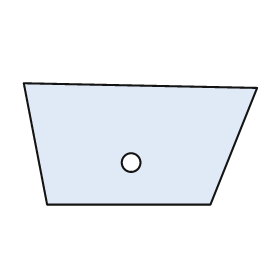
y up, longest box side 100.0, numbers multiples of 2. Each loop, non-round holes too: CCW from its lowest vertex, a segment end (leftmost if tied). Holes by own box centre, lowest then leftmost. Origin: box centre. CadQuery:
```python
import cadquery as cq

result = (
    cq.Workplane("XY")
    .moveTo(-40.0, -26.0)
    .lineTo(30.0, -26.0)
    .lineTo(50.0, 24.0)
    .lineTo(-50.0, 26.0)
    .close()
    .moveTo(-4.0, -8.0)
    .circle(4.0)
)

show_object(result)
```